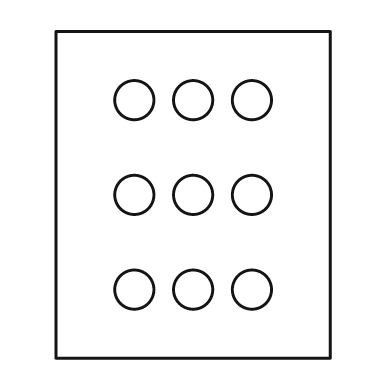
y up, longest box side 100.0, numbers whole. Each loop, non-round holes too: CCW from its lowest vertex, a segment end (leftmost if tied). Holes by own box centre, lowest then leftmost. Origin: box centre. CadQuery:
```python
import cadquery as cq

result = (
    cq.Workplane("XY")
    .moveTo(-42.0, -50.0)
    .lineTo(42.0, -50.0)
    .lineTo(42.0, 50.0)
    .lineTo(-42.0, 50.0)
    .close()
    .moveTo(-18.0, -29.0)
    .circle(6.0)
    .moveTo(0.0, -29.0)
    .circle(6.0)
    .moveTo(18.0, -29.0)
    .circle(6.0)
    .moveTo(-18.0, 0.0)
    .circle(6.0)
    .moveTo(0.0, 0.0)
    .circle(6.0)
    .moveTo(18.0, 0.0)
    .circle(6.0)
    .moveTo(-18.0, 29.0)
    .circle(6.0)
    .moveTo(0.0, 29.0)
    .circle(6.0)
    .moveTo(18.0, 29.0)
    .circle(6.0)
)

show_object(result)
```